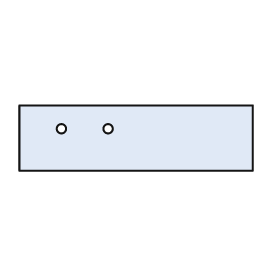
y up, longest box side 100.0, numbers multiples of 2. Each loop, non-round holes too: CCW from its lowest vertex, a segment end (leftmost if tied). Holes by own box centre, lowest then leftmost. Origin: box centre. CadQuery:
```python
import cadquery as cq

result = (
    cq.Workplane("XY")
    .moveTo(-50.0, -14.0)
    .lineTo(50.0, -14.0)
    .lineTo(50.0, 14.0)
    .lineTo(-50.0, 14.0)
    .close()
    .moveTo(-32.0, 4.0)
    .circle(2.0)
    .moveTo(-12.0, 4.0)
    .circle(2.0)
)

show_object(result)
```